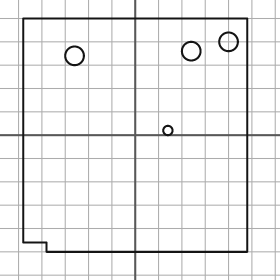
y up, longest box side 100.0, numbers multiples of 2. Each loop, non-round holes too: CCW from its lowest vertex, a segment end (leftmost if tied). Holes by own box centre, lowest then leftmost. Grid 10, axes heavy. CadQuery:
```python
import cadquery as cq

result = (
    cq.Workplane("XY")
    .moveTo(-38.0, -50.0)
    .lineTo(48.0, -50.0)
    .lineTo(48.0, 50.0)
    .lineTo(-48.0, 50.0)
    .lineTo(-48.0, -46.0)
    .lineTo(-38.0, -46.0)
    .close()
    .moveTo(14.0, 2.0)
    .circle(2.0)
    .moveTo(-26.0, 34.0)
    .circle(4.0)
    .moveTo(24.0, 36.0)
    .circle(4.0)
    .moveTo(40.0, 40.0)
    .circle(4.0)
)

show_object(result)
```